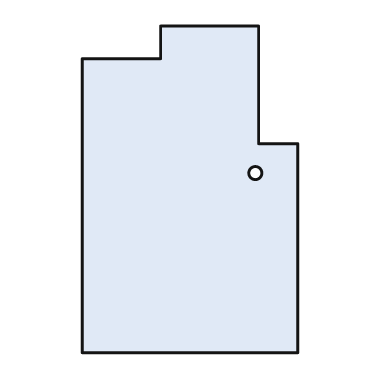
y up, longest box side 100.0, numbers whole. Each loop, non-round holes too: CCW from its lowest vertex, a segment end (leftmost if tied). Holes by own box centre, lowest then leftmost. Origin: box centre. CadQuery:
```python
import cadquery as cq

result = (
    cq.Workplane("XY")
    .moveTo(-33.0, -50.0)
    .lineTo(33.0, -50.0)
    .lineTo(33.0, 14.0)
    .lineTo(21.0, 14.0)
    .lineTo(21.0, 50.0)
    .lineTo(-9.0, 50.0)
    .lineTo(-9.0, 40.0)
    .lineTo(-33.0, 40.0)
    .close()
    .moveTo(20.0, 5.0)
    .circle(2.0)
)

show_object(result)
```